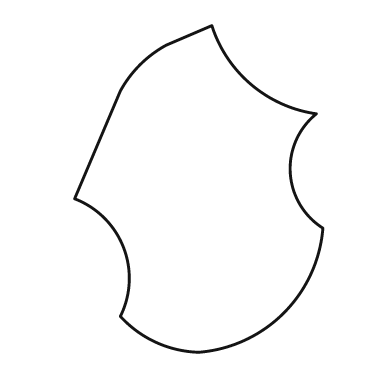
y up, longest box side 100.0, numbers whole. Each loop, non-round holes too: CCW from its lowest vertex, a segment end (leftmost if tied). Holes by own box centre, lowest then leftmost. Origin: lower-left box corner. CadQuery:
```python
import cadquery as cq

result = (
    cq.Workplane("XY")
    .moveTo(38.0, 0.0)
    .threePointArc((64.0, 12.0), (76.0, 38.0))
    .threePointArc((66.0, 55.0), (74.0, 73.0))
    .threePointArc((54.0, 82.0), (42.0, 100.0))
    .lineTo(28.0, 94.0)
    .threePointArc((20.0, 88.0), (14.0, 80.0))
    .lineTo(0.0, 47.0)
    .threePointArc((15.0, 32.0), (14.0, 11.0))
    .threePointArc((25.0, 3.0), (38.0, 0.0))
    .close()
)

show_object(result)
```